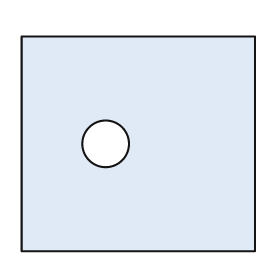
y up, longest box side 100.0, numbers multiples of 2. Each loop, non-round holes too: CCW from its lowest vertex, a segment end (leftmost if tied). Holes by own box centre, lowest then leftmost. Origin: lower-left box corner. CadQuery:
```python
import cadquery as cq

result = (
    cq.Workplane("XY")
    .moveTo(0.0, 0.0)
    .lineTo(100.0, 0.0)
    .lineTo(100.0, 92.0)
    .lineTo(0.0, 92.0)
    .close()
    .moveTo(36.0, 46.0)
    .circle(10.0)
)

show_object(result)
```